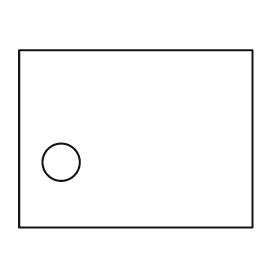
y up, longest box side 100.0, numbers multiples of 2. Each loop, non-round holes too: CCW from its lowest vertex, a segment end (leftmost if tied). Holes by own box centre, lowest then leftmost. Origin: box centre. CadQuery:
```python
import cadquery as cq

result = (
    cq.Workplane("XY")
    .moveTo(-50.0, -38.0)
    .lineTo(50.0, -38.0)
    .lineTo(50.0, 38.0)
    .lineTo(-50.0, 38.0)
    .close()
    .moveTo(-32.0, -10.0)
    .circle(8.0)
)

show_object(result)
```